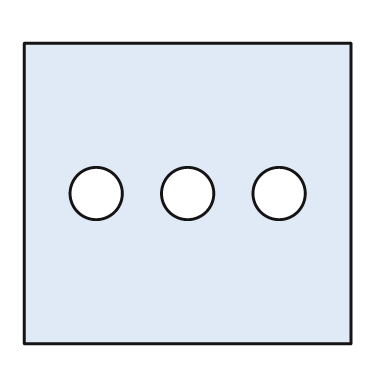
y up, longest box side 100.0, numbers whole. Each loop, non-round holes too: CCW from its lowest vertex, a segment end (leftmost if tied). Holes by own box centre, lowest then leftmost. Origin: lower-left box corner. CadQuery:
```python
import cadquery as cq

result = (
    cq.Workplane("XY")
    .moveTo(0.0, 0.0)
    .lineTo(100.0, 0.0)
    .lineTo(100.0, 92.0)
    .lineTo(0.0, 92.0)
    .close()
    .moveTo(22.0, 46.0)
    .circle(8.0)
    .moveTo(50.0, 46.0)
    .circle(8.0)
    .moveTo(78.0, 46.0)
    .circle(8.0)
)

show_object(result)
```